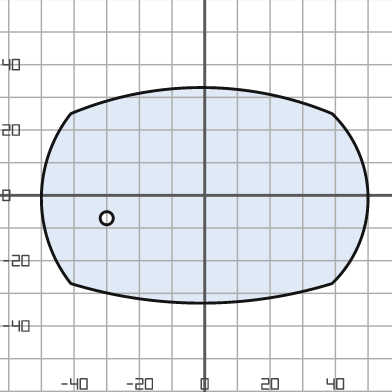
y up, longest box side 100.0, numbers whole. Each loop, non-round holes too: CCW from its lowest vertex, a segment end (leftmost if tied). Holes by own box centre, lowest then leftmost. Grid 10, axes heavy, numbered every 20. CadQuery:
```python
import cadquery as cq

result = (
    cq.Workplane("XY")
    .moveTo(-41.0, -27.0)
    .threePointArc((-1.0, -33.0), (39.0, -27.0))
    .threePointArc((50.0, -1.0), (39.0, 25.0))
    .threePointArc((-1.0, 33.0), (-41.0, 25.0))
    .threePointArc((-50.0, -1.0), (-41.0, -27.0))
    .close()
    .moveTo(-30.0, -7.0)
    .circle(2.0)
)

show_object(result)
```